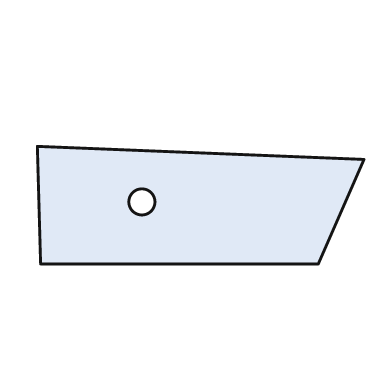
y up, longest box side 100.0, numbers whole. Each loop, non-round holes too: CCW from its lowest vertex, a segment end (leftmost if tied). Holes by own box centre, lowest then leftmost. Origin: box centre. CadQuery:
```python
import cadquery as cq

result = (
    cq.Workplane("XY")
    .moveTo(-49.0, -18.0)
    .lineTo(36.0, -18.0)
    .lineTo(50.0, 14.0)
    .lineTo(-50.0, 18.0)
    .close()
    .moveTo(-18.0, 1.0)
    .circle(4.0)
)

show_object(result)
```